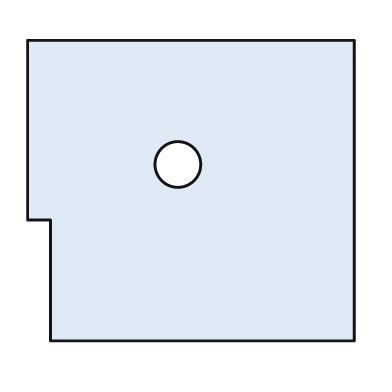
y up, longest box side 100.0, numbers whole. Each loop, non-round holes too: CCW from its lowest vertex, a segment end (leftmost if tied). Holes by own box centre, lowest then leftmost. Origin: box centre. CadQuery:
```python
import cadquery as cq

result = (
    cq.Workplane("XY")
    .moveTo(-43.0, -46.0)
    .lineTo(50.0, -46.0)
    .lineTo(50.0, 46.0)
    .lineTo(-50.0, 46.0)
    .lineTo(-50.0, -9.0)
    .lineTo(-43.0, -9.0)
    .close()
    .moveTo(-4.0, 8.0)
    .circle(7.0)
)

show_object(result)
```